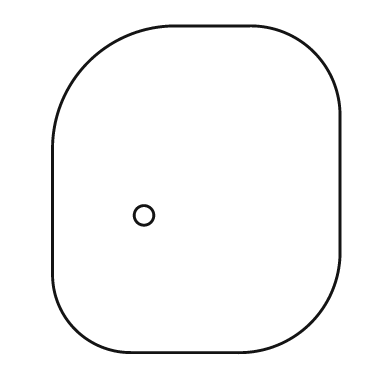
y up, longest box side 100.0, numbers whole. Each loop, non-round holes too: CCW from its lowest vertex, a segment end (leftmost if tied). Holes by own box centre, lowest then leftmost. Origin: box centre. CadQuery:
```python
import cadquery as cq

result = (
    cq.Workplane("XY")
    .moveTo(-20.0, -50.0)
    .lineTo(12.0, -50.0)
    .threePointArc((35.0, -41.0), (44.0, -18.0))
    .lineTo(44.0, 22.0)
    .threePointArc((36.0, 42.0), (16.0, 50.0))
    .lineTo(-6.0, 50.0)
    .threePointArc((-33.0, 39.0), (-44.0, 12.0))
    .lineTo(-44.0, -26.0)
    .threePointArc((-37.0, -43.0), (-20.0, -50.0))
    .close()
    .moveTo(-16.0, -8.0)
    .circle(3.0)
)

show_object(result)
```